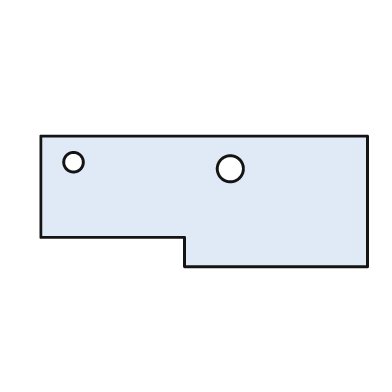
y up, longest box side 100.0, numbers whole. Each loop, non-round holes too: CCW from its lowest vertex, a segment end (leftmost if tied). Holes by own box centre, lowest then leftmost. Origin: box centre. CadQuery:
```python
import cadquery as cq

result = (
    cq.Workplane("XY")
    .moveTo(-6.0, -20.0)
    .lineTo(50.0, -20.0)
    .lineTo(50.0, 20.0)
    .lineTo(-50.0, 20.0)
    .lineTo(-50.0, -11.0)
    .lineTo(-6.0, -11.0)
    .close()
    .moveTo(8.0, 10.0)
    .circle(4.0)
    .moveTo(-40.0, 12.0)
    .circle(3.0)
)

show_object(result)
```